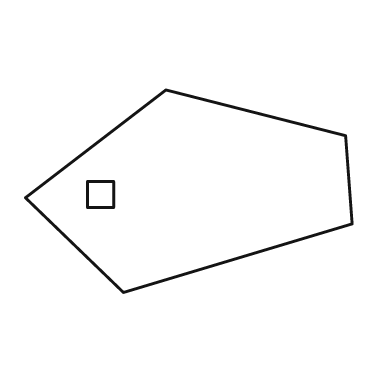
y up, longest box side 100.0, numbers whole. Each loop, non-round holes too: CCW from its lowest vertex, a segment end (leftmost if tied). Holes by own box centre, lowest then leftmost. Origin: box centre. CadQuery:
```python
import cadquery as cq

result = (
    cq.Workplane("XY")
    .moveTo(-20.0, -31.0)
    .lineTo(50.0, -10.0)
    .lineTo(48.0, 17.0)
    .lineTo(-7.0, 31.0)
    .lineTo(-50.0, -2.0)
    .close()
    .moveTo(-31.0, -5.0)
    .lineTo(-23.0, -5.0)
    .lineTo(-23.0, 3.0)
    .lineTo(-31.0, 3.0)
    .close()
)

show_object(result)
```